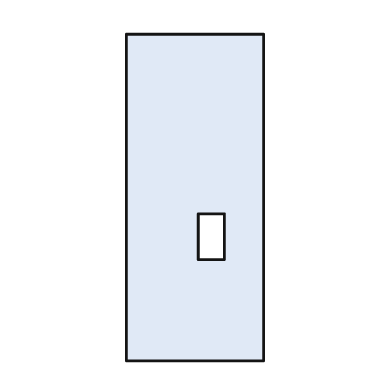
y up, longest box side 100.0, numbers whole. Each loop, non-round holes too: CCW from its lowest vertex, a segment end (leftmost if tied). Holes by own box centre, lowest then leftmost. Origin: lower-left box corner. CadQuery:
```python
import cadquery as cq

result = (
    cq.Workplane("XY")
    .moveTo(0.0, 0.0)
    .lineTo(42.0, 0.0)
    .lineTo(42.0, 100.0)
    .lineTo(0.0, 100.0)
    .close()
    .moveTo(22.0, 31.0)
    .lineTo(30.0, 31.0)
    .lineTo(30.0, 45.0)
    .lineTo(22.0, 45.0)
    .close()
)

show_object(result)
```